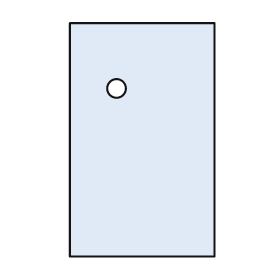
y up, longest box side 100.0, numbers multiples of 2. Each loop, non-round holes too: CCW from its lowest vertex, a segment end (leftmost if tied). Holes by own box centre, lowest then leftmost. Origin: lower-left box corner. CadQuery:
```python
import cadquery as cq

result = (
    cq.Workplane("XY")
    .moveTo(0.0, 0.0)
    .lineTo(62.0, 0.0)
    .lineTo(62.0, 100.0)
    .lineTo(0.0, 100.0)
    .close()
    .moveTo(20.0, 72.0)
    .circle(4.0)
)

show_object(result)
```